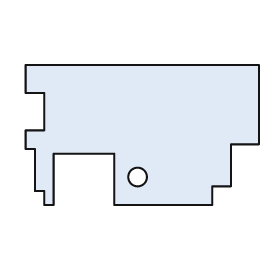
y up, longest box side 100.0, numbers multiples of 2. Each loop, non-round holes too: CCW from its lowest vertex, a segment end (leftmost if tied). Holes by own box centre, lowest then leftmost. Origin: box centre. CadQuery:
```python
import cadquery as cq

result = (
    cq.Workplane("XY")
    .moveTo(-42.0, -30.0)
    .lineTo(-38.0, -30.0)
    .lineTo(-38.0, -8.0)
    .lineTo(-12.0, -8.0)
    .lineTo(-12.0, -30.0)
    .lineTo(30.0, -30.0)
    .lineTo(30.0, -22.0)
    .lineTo(38.0, -22.0)
    .lineTo(38.0, -4.0)
    .lineTo(50.0, -4.0)
    .lineTo(50.0, 30.0)
    .lineTo(-50.0, 30.0)
    .lineTo(-50.0, 18.0)
    .lineTo(-42.0, 18.0)
    .lineTo(-42.0, 2.0)
    .lineTo(-50.0, 2.0)
    .lineTo(-50.0, -6.0)
    .lineTo(-46.0, -6.0)
    .lineTo(-46.0, -24.0)
    .lineTo(-42.0, -24.0)
    .close()
    .moveTo(-2.0, -18.0)
    .circle(4.0)
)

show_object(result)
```